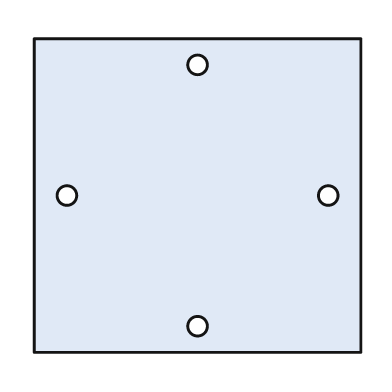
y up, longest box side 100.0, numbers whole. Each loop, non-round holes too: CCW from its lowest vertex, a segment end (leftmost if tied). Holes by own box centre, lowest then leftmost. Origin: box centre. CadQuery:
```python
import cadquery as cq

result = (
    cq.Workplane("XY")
    .moveTo(-50.0, -48.0)
    .lineTo(50.0, -48.0)
    .lineTo(50.0, 48.0)
    .lineTo(-50.0, 48.0)
    .close()
    .moveTo(0.0, -40.0)
    .circle(3.0)
    .moveTo(-40.0, 0.0)
    .circle(3.0)
    .moveTo(40.0, 0.0)
    .circle(3.0)
    .moveTo(0.0, 40.0)
    .circle(3.0)
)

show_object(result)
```